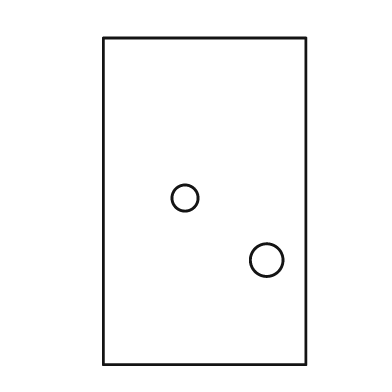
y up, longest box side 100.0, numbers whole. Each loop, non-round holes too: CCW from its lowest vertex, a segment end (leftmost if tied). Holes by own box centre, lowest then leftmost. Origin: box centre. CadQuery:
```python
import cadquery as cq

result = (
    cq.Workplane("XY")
    .moveTo(-31.0, -50.0)
    .lineTo(31.0, -50.0)
    .lineTo(31.0, 50.0)
    .lineTo(-31.0, 50.0)
    .close()
    .moveTo(19.0, -18.0)
    .circle(5.0)
    .moveTo(-6.0, 1.0)
    .circle(4.0)
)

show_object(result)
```